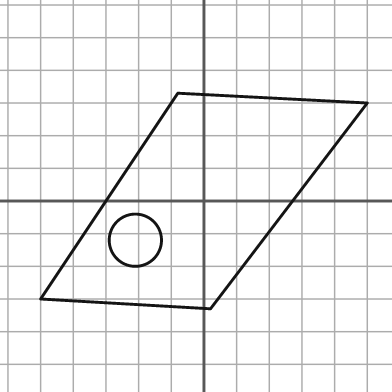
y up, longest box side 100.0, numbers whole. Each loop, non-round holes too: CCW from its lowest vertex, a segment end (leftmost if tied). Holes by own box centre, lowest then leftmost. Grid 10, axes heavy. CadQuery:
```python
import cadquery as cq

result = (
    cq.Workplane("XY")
    .moveTo(2.0, -33.0)
    .lineTo(50.0, 30.0)
    .lineTo(-8.0, 33.0)
    .lineTo(-50.0, -30.0)
    .close()
    .moveTo(-21.0, -12.0)
    .circle(8.0)
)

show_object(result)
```